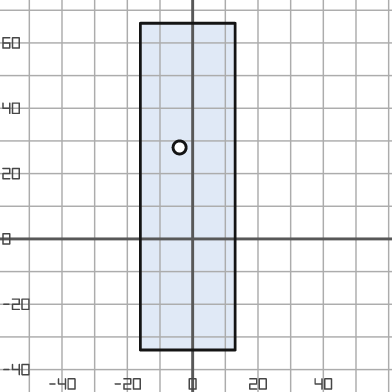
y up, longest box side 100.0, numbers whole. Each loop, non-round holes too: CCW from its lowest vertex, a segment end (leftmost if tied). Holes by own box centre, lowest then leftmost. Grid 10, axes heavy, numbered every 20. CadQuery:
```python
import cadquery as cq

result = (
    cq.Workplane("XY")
    .moveTo(-16.0, -34.0)
    .lineTo(13.0, -34.0)
    .lineTo(13.0, 66.0)
    .lineTo(-16.0, 66.0)
    .close()
    .moveTo(-4.0, 28.0)
    .circle(2.0)
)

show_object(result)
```